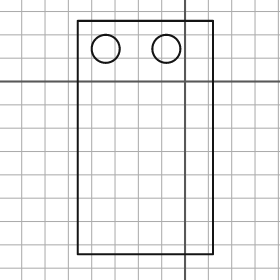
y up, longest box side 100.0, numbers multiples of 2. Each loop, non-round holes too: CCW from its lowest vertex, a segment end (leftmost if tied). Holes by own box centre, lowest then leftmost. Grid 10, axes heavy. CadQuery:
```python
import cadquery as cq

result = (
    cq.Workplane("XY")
    .moveTo(-46.0, -74.0)
    .lineTo(12.0, -74.0)
    .lineTo(12.0, 26.0)
    .lineTo(-46.0, 26.0)
    .close()
    .moveTo(-34.0, 14.0)
    .circle(6.0)
    .moveTo(-8.0, 14.0)
    .circle(6.0)
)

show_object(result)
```